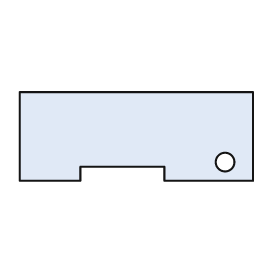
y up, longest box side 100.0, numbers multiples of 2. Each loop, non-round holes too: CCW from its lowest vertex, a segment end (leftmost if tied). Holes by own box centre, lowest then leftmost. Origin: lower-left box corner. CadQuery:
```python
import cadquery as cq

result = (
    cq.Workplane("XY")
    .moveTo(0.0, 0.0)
    .lineTo(26.0, 0.0)
    .lineTo(26.0, 6.0)
    .lineTo(62.0, 6.0)
    .lineTo(62.0, 0.0)
    .lineTo(100.0, 0.0)
    .lineTo(100.0, 38.0)
    .lineTo(0.0, 38.0)
    .close()
    .moveTo(88.0, 8.0)
    .circle(4.0)
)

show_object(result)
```